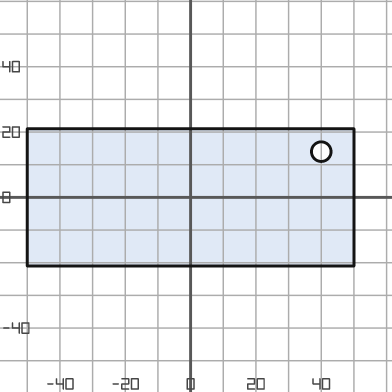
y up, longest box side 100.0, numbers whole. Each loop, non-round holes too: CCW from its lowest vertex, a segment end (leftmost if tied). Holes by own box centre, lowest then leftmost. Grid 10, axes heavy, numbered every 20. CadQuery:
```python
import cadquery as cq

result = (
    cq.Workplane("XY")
    .moveTo(-50.0, -21.0)
    .lineTo(50.0, -21.0)
    .lineTo(50.0, 21.0)
    .lineTo(-50.0, 21.0)
    .close()
    .moveTo(40.0, 14.0)
    .circle(3.0)
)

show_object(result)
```